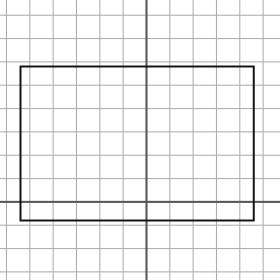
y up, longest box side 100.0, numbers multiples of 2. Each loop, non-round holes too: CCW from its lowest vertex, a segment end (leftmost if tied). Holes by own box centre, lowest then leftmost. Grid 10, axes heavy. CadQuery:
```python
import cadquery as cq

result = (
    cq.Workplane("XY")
    .moveTo(-54.0, -8.0)
    .lineTo(46.0, -8.0)
    .lineTo(46.0, 58.0)
    .lineTo(-54.0, 58.0)
    .close()
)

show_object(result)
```